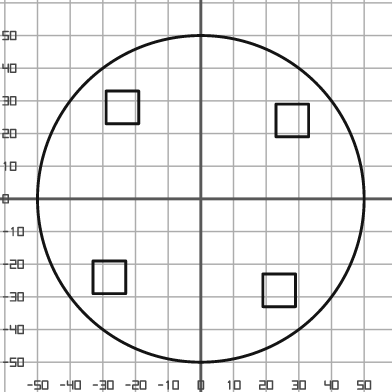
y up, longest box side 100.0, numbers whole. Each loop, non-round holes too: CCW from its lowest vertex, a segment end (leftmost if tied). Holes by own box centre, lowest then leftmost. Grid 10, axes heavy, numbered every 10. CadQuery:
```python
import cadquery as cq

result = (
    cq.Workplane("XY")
    .moveTo(0.0, 0.0)
    .circle(50.0)
    .moveTo(19.0, -33.0)
    .lineTo(29.0, -33.0)
    .lineTo(29.0, -23.0)
    .lineTo(19.0, -23.0)
    .close()
    .moveTo(-33.0, -29.0)
    .lineTo(-23.0, -29.0)
    .lineTo(-23.0, -19.0)
    .lineTo(-33.0, -19.0)
    .close()
    .moveTo(23.0, 19.0)
    .lineTo(33.0, 19.0)
    .lineTo(33.0, 29.0)
    .lineTo(23.0, 29.0)
    .close()
    .moveTo(-29.0, 23.0)
    .lineTo(-19.0, 23.0)
    .lineTo(-19.0, 33.0)
    .lineTo(-29.0, 33.0)
    .close()
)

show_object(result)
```